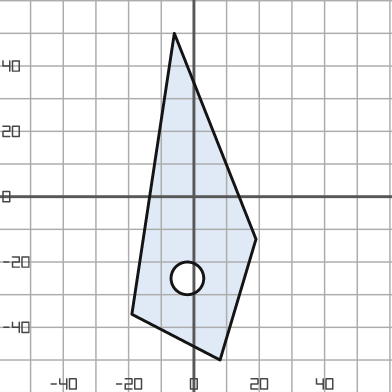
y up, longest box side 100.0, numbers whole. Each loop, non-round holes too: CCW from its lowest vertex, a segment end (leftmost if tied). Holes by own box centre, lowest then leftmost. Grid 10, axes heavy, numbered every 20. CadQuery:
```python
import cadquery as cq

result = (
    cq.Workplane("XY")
    .moveTo(8.0, -50.0)
    .lineTo(19.0, -13.0)
    .lineTo(-6.0, 50.0)
    .lineTo(-19.0, -36.0)
    .close()
    .moveTo(-2.0, -25.0)
    .circle(5.0)
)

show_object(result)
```